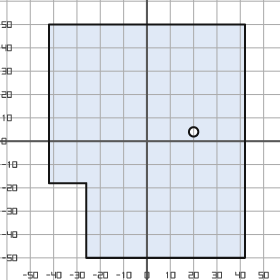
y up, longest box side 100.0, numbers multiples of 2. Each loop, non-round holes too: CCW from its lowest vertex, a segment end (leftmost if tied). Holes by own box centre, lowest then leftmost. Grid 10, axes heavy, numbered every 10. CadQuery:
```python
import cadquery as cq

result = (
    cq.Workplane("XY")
    .moveTo(-26.0, -50.0)
    .lineTo(42.0, -50.0)
    .lineTo(42.0, 50.0)
    .lineTo(-42.0, 50.0)
    .lineTo(-42.0, -18.0)
    .lineTo(-26.0, -18.0)
    .close()
    .moveTo(20.0, 4.0)
    .circle(2.0)
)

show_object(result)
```